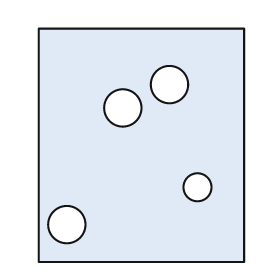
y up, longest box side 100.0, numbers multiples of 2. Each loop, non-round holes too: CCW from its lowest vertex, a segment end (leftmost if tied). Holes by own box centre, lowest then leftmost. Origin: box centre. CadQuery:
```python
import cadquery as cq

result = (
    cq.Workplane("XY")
    .moveTo(-44.0, -50.0)
    .lineTo(44.0, -50.0)
    .lineTo(44.0, 50.0)
    .lineTo(-44.0, 50.0)
    .close()
    .moveTo(-32.0, -34.0)
    .circle(8.0)
    .moveTo(24.0, -18.0)
    .circle(6.0)
    .moveTo(-8.0, 16.0)
    .circle(8.0)
    .moveTo(12.0, 26.0)
    .circle(8.0)
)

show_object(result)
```